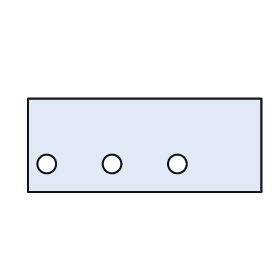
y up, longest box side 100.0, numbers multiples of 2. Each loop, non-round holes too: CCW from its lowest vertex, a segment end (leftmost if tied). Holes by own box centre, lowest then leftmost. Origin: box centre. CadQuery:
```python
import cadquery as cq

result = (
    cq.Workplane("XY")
    .moveTo(-50.0, -20.0)
    .lineTo(50.0, -20.0)
    .lineTo(50.0, 20.0)
    .lineTo(-50.0, 20.0)
    .close()
    .moveTo(-42.0, -8.0)
    .circle(4.0)
    .moveTo(-14.0, -8.0)
    .circle(4.0)
    .moveTo(14.0, -8.0)
    .circle(4.0)
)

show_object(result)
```